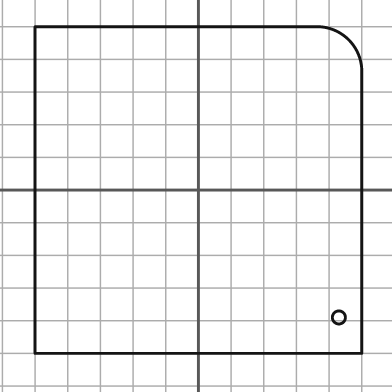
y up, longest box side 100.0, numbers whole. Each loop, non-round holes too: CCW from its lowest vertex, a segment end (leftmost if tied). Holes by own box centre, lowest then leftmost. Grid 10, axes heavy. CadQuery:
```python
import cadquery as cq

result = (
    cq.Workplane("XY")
    .moveTo(-50.0, -50.0)
    .lineTo(50.0, -50.0)
    .lineTo(50.0, 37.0)
    .threePointArc((46.0, 46.0), (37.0, 50.0))
    .lineTo(-50.0, 50.0)
    .close()
    .moveTo(43.0, -39.0)
    .circle(2.0)
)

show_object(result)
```